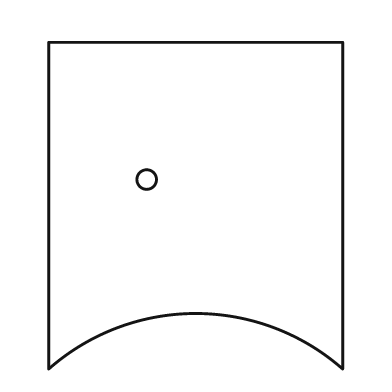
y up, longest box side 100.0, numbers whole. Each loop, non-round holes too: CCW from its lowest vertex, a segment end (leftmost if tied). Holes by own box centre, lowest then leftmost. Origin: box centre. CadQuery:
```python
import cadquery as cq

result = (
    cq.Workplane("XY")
    .moveTo(-45.0, -50.0)
    .threePointArc((0.0, -33.0), (45.0, -50.0))
    .lineTo(45.0, 50.0)
    .lineTo(-45.0, 50.0)
    .close()
    .moveTo(-15.0, 8.0)
    .circle(3.0)
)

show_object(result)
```